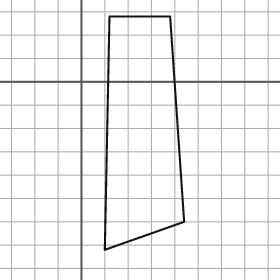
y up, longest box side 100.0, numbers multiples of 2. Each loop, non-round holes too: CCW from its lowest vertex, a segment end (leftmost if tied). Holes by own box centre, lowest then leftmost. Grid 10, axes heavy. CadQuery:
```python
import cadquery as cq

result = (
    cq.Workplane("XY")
    .moveTo(10.0, -72.0)
    .lineTo(44.0, -60.0)
    .lineTo(38.0, 28.0)
    .lineTo(12.0, 28.0)
    .close()
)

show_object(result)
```